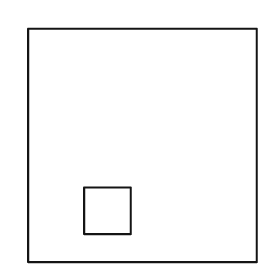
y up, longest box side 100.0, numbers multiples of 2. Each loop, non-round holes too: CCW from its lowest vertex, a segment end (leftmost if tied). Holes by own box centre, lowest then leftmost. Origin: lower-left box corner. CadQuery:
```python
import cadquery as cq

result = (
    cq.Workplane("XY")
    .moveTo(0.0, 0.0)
    .lineTo(98.0, 0.0)
    .lineTo(98.0, 100.0)
    .lineTo(0.0, 100.0)
    .close()
    .moveTo(24.0, 12.0)
    .lineTo(44.0, 12.0)
    .lineTo(44.0, 32.0)
    .lineTo(24.0, 32.0)
    .close()
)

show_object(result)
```